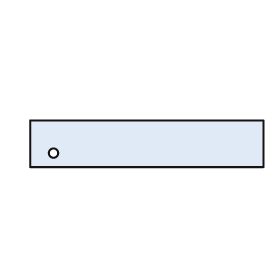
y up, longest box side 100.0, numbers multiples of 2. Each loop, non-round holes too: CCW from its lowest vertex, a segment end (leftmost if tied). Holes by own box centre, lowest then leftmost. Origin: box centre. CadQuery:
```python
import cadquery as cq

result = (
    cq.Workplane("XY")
    .moveTo(-50.0, -10.0)
    .lineTo(50.0, -10.0)
    .lineTo(50.0, 10.0)
    .lineTo(-50.0, 10.0)
    .close()
    .moveTo(-40.0, -4.0)
    .circle(2.0)
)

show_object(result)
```